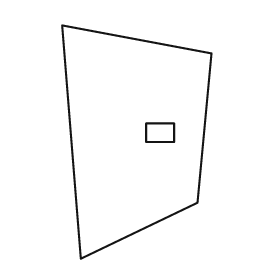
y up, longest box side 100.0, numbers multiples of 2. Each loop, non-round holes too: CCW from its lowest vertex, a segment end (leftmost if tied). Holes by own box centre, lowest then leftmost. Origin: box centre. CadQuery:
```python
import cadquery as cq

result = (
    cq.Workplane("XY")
    .moveTo(-24.0, -50.0)
    .lineTo(26.0, -26.0)
    .lineTo(32.0, 38.0)
    .lineTo(-32.0, 50.0)
    .close()
    .moveTo(4.0, 0.0)
    .lineTo(16.0, 0.0)
    .lineTo(16.0, 8.0)
    .lineTo(4.0, 8.0)
    .close()
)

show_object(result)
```